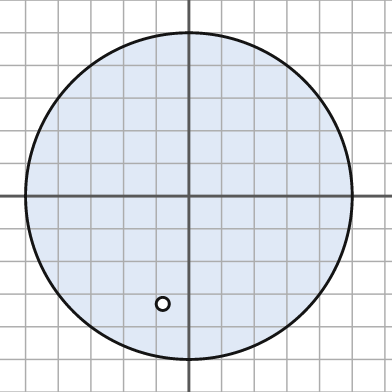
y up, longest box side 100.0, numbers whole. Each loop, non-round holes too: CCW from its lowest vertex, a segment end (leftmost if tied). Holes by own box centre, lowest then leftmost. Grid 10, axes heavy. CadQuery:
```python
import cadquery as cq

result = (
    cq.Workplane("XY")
    .moveTo(0.0, 0.0)
    .circle(50.0)
    .moveTo(-8.0, -33.0)
    .circle(2.0)
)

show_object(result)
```